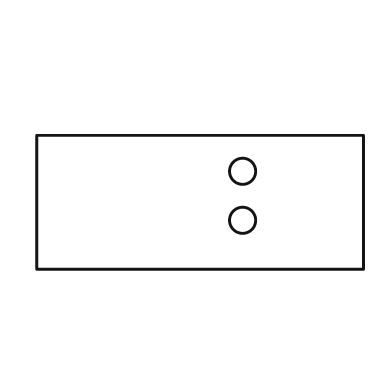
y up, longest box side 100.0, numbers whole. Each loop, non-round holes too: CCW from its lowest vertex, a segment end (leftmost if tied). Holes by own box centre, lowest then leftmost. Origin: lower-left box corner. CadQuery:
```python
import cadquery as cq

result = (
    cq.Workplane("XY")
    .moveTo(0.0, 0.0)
    .lineTo(100.0, 0.0)
    .lineTo(100.0, 41.0)
    .lineTo(0.0, 41.0)
    .close()
    .moveTo(63.0, 15.0)
    .circle(4.0)
    .moveTo(63.0, 30.0)
    .circle(4.0)
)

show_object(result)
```